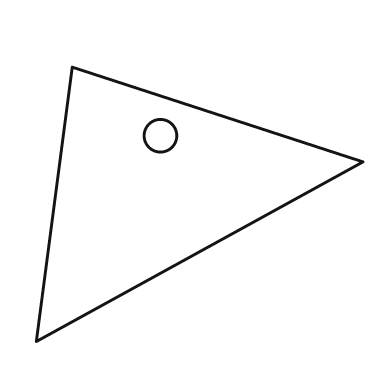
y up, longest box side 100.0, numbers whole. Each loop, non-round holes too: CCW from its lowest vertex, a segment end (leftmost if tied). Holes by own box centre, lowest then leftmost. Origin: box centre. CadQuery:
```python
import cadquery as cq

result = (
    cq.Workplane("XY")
    .moveTo(-50.0, -42.0)
    .lineTo(50.0, 13.0)
    .lineTo(-39.0, 42.0)
    .close()
    .moveTo(-12.0, 21.0)
    .circle(5.0)
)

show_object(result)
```